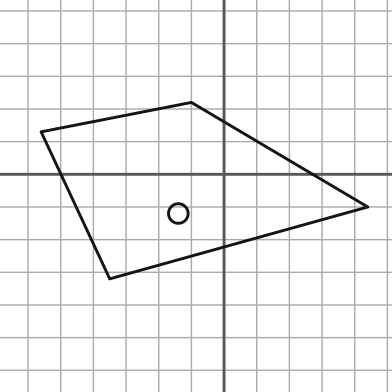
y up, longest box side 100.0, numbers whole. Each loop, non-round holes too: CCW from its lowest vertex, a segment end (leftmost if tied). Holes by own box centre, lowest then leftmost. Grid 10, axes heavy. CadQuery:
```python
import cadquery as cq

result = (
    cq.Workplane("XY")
    .moveTo(-35.0, -32.0)
    .lineTo(44.0, -10.0)
    .lineTo(-10.0, 22.0)
    .lineTo(-56.0, 13.0)
    .close()
    .moveTo(-14.0, -12.0)
    .circle(3.0)
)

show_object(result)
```